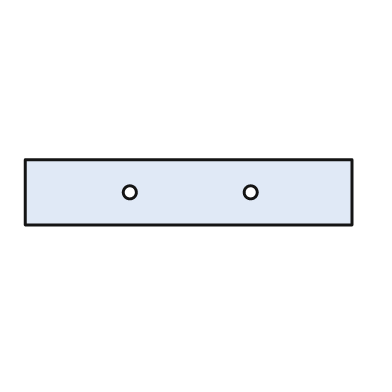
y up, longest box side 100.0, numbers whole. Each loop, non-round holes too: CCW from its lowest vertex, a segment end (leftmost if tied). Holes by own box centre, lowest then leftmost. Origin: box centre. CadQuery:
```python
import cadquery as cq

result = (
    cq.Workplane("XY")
    .moveTo(-50.0, -10.0)
    .lineTo(50.0, -10.0)
    .lineTo(50.0, 10.0)
    .lineTo(-50.0, 10.0)
    .close()
    .moveTo(-18.0, 0.0)
    .circle(2.0)
    .moveTo(19.0, 0.0)
    .circle(2.0)
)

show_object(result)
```